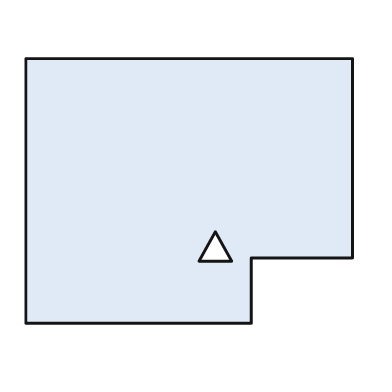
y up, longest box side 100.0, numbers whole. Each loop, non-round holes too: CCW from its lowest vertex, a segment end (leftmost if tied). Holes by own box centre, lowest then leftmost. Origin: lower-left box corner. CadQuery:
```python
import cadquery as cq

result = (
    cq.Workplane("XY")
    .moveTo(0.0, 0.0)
    .lineTo(69.0, 0.0)
    .lineTo(69.0, 20.0)
    .lineTo(100.0, 20.0)
    .lineTo(100.0, 81.0)
    .lineTo(0.0, 81.0)
    .close()
    .moveTo(53.0, 19.0)
    .lineTo(63.0, 19.0)
    .lineTo(58.0, 28.0)
    .close()
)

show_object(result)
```